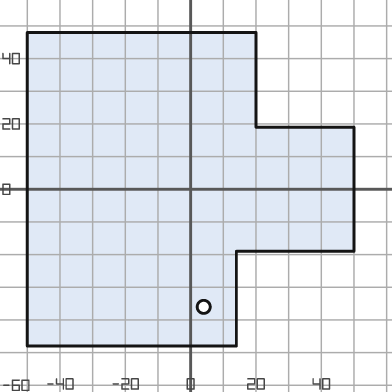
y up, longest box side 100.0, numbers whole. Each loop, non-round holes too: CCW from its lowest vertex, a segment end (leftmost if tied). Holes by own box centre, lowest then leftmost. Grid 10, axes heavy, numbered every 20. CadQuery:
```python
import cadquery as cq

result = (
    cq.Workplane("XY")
    .moveTo(-50.0, -48.0)
    .lineTo(14.0, -48.0)
    .lineTo(14.0, -19.0)
    .lineTo(50.0, -19.0)
    .lineTo(50.0, 19.0)
    .lineTo(20.0, 19.0)
    .lineTo(20.0, 48.0)
    .lineTo(-50.0, 48.0)
    .close()
    .moveTo(4.0, -36.0)
    .circle(2.0)
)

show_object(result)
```